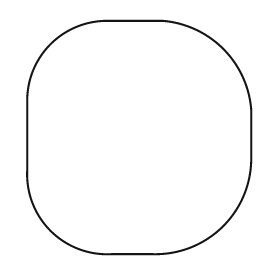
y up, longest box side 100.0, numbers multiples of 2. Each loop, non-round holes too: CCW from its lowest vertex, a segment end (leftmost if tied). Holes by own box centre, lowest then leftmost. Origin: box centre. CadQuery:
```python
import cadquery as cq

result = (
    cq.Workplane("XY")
    .moveTo(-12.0, -50.0)
    .lineTo(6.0, -50.0)
    .threePointArc((36.0, -38.0), (48.0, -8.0))
    .lineTo(48.0, 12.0)
    .threePointArc((36.0, 38.0), (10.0, 50.0))
    .lineTo(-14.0, 50.0)
    .threePointArc((-38.0, 40.0), (-48.0, 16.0))
    .lineTo(-48.0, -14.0)
    .threePointArc((-38.0, -40.0), (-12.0, -50.0))
    .close()
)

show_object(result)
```